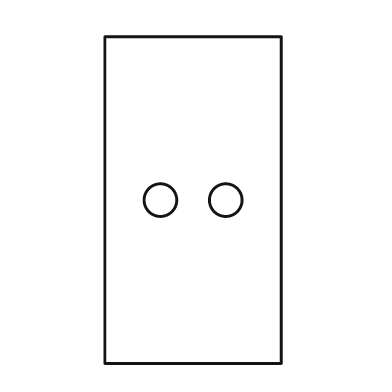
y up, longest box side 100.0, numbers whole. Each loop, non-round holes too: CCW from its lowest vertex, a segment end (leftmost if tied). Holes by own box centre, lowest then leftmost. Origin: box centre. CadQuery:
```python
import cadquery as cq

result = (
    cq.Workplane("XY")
    .moveTo(-27.0, -50.0)
    .lineTo(27.0, -50.0)
    .lineTo(27.0, 50.0)
    .lineTo(-27.0, 50.0)
    .close()
    .moveTo(-10.0, 0.0)
    .circle(5.0)
    .moveTo(10.0, 0.0)
    .circle(5.0)
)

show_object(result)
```